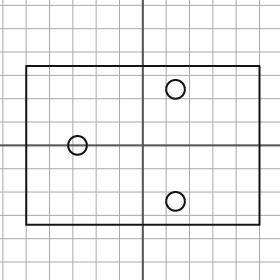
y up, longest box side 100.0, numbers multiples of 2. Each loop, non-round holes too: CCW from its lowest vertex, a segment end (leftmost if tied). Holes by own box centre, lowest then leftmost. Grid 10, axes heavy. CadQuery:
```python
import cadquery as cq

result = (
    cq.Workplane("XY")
    .moveTo(-50.0, -34.0)
    .lineTo(50.0, -34.0)
    .lineTo(50.0, 34.0)
    .lineTo(-50.0, 34.0)
    .close()
    .moveTo(14.0, -24.0)
    .circle(4.0)
    .moveTo(-28.0, 0.0)
    .circle(4.0)
    .moveTo(14.0, 24.0)
    .circle(4.0)
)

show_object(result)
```